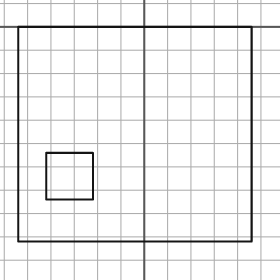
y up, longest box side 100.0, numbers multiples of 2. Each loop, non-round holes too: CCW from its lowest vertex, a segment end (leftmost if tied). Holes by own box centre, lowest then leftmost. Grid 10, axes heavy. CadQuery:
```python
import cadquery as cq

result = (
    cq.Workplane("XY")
    .moveTo(-54.0, -92.0)
    .lineTo(46.0, -92.0)
    .lineTo(46.0, 0.0)
    .lineTo(-54.0, 0.0)
    .close()
    .moveTo(-42.0, -74.0)
    .lineTo(-22.0, -74.0)
    .lineTo(-22.0, -54.0)
    .lineTo(-42.0, -54.0)
    .close()
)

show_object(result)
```